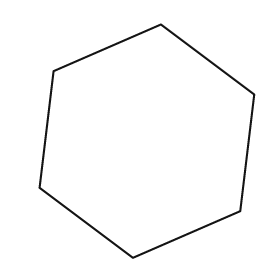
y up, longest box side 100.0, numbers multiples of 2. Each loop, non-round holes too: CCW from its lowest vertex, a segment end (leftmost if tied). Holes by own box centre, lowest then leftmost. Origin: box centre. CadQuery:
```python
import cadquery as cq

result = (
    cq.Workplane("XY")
    .moveTo(-6.0, -50.0)
    .lineTo(40.0, -30.0)
    .lineTo(46.0, 20.0)
    .lineTo(6.0, 50.0)
    .lineTo(-40.0, 30.0)
    .lineTo(-46.0, -20.0)
    .close()
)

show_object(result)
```